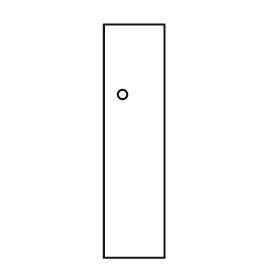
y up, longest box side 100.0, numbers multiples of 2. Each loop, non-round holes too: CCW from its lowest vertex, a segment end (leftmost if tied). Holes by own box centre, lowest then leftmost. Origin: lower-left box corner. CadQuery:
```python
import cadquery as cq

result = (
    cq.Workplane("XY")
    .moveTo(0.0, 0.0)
    .lineTo(26.0, 0.0)
    .lineTo(26.0, 100.0)
    .lineTo(0.0, 100.0)
    .close()
    .moveTo(8.0, 70.0)
    .circle(2.0)
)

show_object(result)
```